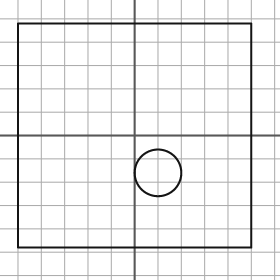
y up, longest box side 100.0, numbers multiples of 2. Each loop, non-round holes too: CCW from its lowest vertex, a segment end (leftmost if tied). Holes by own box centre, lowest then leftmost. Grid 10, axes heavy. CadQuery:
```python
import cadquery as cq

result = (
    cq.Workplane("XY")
    .moveTo(-50.0, -48.0)
    .lineTo(50.0, -48.0)
    .lineTo(50.0, 48.0)
    .lineTo(-50.0, 48.0)
    .close()
    .moveTo(10.0, -16.0)
    .circle(10.0)
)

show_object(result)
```